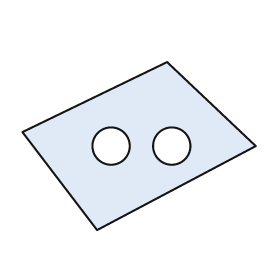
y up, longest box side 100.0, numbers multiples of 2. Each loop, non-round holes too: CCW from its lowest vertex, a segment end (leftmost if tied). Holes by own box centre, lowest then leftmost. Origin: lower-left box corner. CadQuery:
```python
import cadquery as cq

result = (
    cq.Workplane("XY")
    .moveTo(32.0, 0.0)
    .lineTo(100.0, 36.0)
    .lineTo(62.0, 72.0)
    .lineTo(0.0, 42.0)
    .close()
    .moveTo(38.0, 36.0)
    .circle(8.0)
    .moveTo(64.0, 36.0)
    .circle(8.0)
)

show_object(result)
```